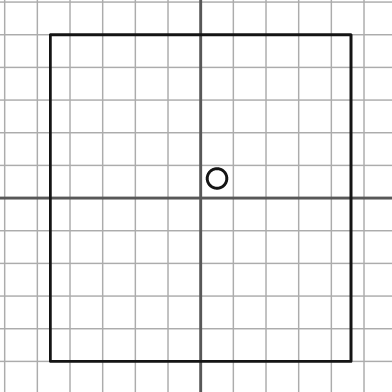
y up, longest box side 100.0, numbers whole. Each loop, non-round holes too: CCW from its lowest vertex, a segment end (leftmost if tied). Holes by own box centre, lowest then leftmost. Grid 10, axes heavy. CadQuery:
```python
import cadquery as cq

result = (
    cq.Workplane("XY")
    .moveTo(-46.0, -50.0)
    .lineTo(46.0, -50.0)
    .lineTo(46.0, 50.0)
    .lineTo(-46.0, 50.0)
    .close()
    .moveTo(5.0, 6.0)
    .circle(3.0)
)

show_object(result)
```